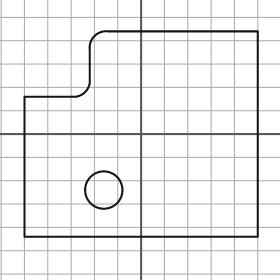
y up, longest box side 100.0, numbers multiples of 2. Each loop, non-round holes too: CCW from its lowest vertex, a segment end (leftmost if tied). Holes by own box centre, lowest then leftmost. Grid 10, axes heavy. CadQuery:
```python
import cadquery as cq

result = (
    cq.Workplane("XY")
    .moveTo(-50.0, -44.0)
    .lineTo(50.0, -44.0)
    .lineTo(50.0, 44.0)
    .lineTo(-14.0, 44.0)
    .threePointArc((-20.0, 42.0), (-22.0, 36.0))
    .lineTo(-22.0, 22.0)
    .threePointArc((-24.0, 18.0), (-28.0, 16.0))
    .lineTo(-50.0, 16.0)
    .close()
    .moveTo(-16.0, -24.0)
    .circle(8.0)
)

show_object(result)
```